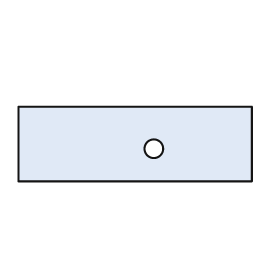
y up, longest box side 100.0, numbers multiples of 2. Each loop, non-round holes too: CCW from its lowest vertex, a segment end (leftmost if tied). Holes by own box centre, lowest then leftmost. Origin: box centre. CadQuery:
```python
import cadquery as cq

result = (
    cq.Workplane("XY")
    .moveTo(-50.0, -16.0)
    .lineTo(50.0, -16.0)
    .lineTo(50.0, 16.0)
    .lineTo(-50.0, 16.0)
    .close()
    .moveTo(8.0, -2.0)
    .circle(4.0)
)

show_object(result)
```